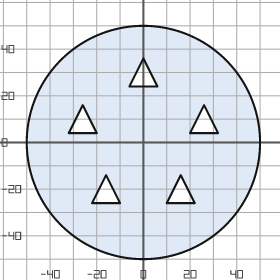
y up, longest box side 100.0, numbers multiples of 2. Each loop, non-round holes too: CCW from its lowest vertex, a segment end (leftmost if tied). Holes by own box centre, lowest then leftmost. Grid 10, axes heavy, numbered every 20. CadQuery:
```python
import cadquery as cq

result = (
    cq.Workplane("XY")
    .moveTo(0.0, 0.0)
    .circle(50.0)
    .moveTo(-22.0, -26.0)
    .lineTo(-10.0, -26.0)
    .lineTo(-16.0, -14.0)
    .close()
    .moveTo(10.0, -26.0)
    .lineTo(22.0, -26.0)
    .lineTo(16.0, -14.0)
    .close()
    .moveTo(-32.0, 4.0)
    .lineTo(-20.0, 4.0)
    .lineTo(-26.0, 16.0)
    .close()
    .moveTo(20.0, 4.0)
    .lineTo(32.0, 4.0)
    .lineTo(26.0, 16.0)
    .close()
    .moveTo(-6.0, 24.0)
    .lineTo(6.0, 24.0)
    .lineTo(0.0, 36.0)
    .close()
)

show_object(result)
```